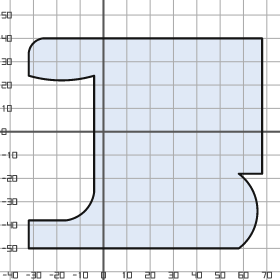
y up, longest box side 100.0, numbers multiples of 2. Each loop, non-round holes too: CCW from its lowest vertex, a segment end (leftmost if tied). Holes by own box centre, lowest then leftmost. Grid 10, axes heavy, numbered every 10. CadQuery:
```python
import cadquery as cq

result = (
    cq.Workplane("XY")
    .moveTo(-32.0, -50.0)
    .lineTo(58.0, -50.0)
    .threePointArc((66.0, -34.0), (58.0, -18.0))
    .lineTo(68.0, -18.0)
    .lineTo(68.0, 40.0)
    .lineTo(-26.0, 40.0)
    .threePointArc((-30.0, 38.0), (-32.0, 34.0))
    .lineTo(-32.0, 24.0)
    .threePointArc((-18.0, 22.0), (-4.0, 24.0))
    .lineTo(-4.0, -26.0)
    .threePointArc((-8.0, -34.0), (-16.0, -38.0))
    .lineTo(-32.0, -38.0)
    .close()
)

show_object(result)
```